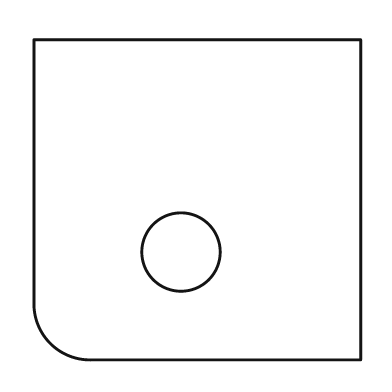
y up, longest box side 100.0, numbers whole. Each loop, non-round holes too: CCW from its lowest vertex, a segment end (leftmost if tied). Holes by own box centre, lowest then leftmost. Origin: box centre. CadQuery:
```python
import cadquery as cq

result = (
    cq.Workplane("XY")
    .moveTo(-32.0, -49.0)
    .lineTo(50.0, -49.0)
    .lineTo(50.0, 49.0)
    .lineTo(-50.0, 49.0)
    .lineTo(-50.0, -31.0)
    .threePointArc((-45.0, -44.0), (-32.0, -49.0))
    .close()
    .moveTo(-5.0, -16.0)
    .circle(12.0)
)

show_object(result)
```